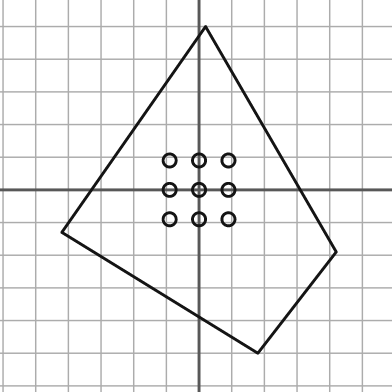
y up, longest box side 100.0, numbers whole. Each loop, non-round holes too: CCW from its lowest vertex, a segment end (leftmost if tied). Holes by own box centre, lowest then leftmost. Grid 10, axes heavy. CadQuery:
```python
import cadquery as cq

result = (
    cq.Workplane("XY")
    .moveTo(18.0, -50.0)
    .lineTo(42.0, -19.0)
    .lineTo(2.0, 50.0)
    .lineTo(-42.0, -13.0)
    .close()
    .moveTo(-9.0, -9.0)
    .circle(2.0)
    .moveTo(0.0, -9.0)
    .circle(2.0)
    .moveTo(9.0, -9.0)
    .circle(2.0)
    .moveTo(-9.0, 0.0)
    .circle(2.0)
    .moveTo(0.0, 0.0)
    .circle(2.0)
    .moveTo(9.0, 0.0)
    .circle(2.0)
    .moveTo(-9.0, 9.0)
    .circle(2.0)
    .moveTo(0.0, 9.0)
    .circle(2.0)
    .moveTo(9.0, 9.0)
    .circle(2.0)
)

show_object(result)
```